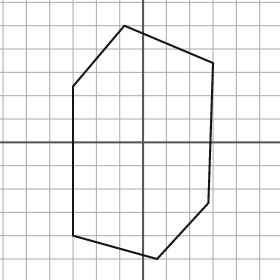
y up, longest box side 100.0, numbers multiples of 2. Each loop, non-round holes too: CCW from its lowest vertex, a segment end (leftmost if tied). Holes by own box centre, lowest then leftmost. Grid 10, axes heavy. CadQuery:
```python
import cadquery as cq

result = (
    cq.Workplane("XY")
    .moveTo(6.0, -50.0)
    .lineTo(28.0, -26.0)
    .lineTo(30.0, 34.0)
    .lineTo(-8.0, 50.0)
    .lineTo(-30.0, 24.0)
    .lineTo(-30.0, -40.0)
    .close()
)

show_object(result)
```